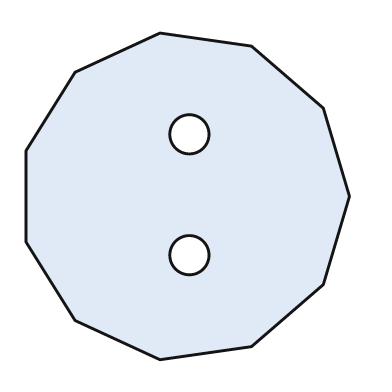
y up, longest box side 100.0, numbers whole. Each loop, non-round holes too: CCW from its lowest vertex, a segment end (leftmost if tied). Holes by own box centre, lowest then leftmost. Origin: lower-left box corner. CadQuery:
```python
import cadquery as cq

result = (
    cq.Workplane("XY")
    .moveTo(41.0, 0.0)
    .lineTo(69.0, 4.0)
    .lineTo(91.0, 23.0)
    .lineTo(99.0, 50.0)
    .lineTo(91.0, 77.0)
    .lineTo(69.0, 96.0)
    .lineTo(41.0, 100.0)
    .lineTo(15.0, 88.0)
    .lineTo(0.0, 64.0)
    .lineTo(0.0, 36.0)
    .lineTo(15.0, 12.0)
    .close()
    .moveTo(50.0, 32.0)
    .circle(6.0)
    .moveTo(50.0, 69.0)
    .circle(6.0)
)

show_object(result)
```